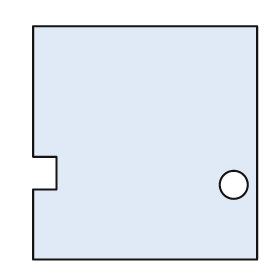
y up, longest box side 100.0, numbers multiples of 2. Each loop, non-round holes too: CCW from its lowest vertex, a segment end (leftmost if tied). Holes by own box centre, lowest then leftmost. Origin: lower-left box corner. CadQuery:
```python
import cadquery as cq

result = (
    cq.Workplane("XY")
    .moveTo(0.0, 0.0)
    .lineTo(96.0, 0.0)
    .lineTo(96.0, 100.0)
    .lineTo(0.0, 100.0)
    .lineTo(0.0, 44.0)
    .lineTo(10.0, 44.0)
    .lineTo(10.0, 30.0)
    .lineTo(0.0, 30.0)
    .close()
    .moveTo(86.0, 32.0)
    .circle(6.0)
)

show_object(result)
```